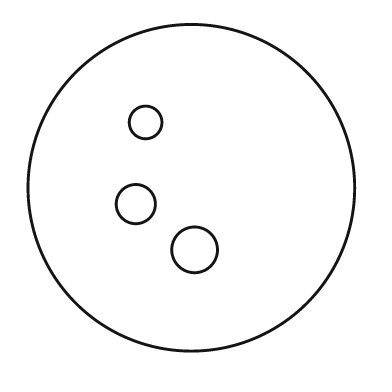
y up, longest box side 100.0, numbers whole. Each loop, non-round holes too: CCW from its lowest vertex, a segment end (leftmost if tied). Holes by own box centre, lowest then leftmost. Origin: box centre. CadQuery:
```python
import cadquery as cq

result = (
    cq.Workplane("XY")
    .moveTo(0.0, 0.0)
    .circle(50.0)
    .moveTo(1.0, -19.0)
    .circle(7.0)
    .moveTo(-17.0, -5.0)
    .circle(6.0)
    .moveTo(-14.0, 20.0)
    .circle(5.0)
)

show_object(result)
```